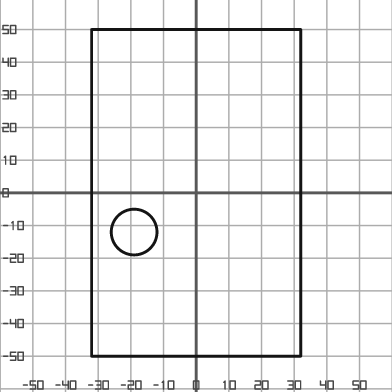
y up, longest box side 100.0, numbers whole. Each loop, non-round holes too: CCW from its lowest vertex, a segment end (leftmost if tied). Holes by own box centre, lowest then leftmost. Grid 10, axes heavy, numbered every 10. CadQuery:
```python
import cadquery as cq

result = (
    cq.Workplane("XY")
    .moveTo(-32.0, -50.0)
    .lineTo(32.0, -50.0)
    .lineTo(32.0, 50.0)
    .lineTo(-32.0, 50.0)
    .close()
    .moveTo(-19.0, -12.0)
    .circle(7.0)
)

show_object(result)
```